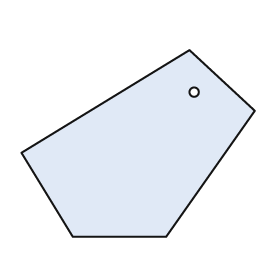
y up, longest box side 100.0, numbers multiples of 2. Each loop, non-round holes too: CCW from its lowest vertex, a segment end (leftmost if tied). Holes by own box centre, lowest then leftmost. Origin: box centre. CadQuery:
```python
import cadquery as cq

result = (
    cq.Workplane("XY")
    .moveTo(-28.0, -40.0)
    .lineTo(12.0, -40.0)
    .lineTo(50.0, 14.0)
    .lineTo(22.0, 40.0)
    .lineTo(-50.0, -4.0)
    .close()
    .moveTo(24.0, 22.0)
    .circle(2.0)
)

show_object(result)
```